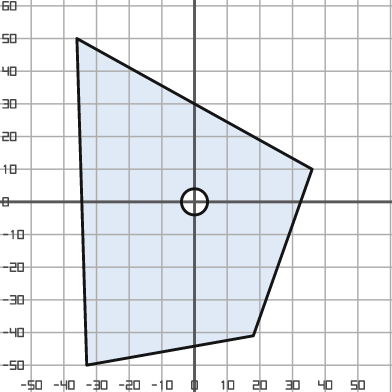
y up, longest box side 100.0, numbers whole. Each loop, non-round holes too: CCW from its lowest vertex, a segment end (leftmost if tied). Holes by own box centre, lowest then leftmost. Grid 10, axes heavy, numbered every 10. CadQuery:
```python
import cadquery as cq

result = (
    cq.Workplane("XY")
    .moveTo(-33.0, -50.0)
    .lineTo(18.0, -41.0)
    .lineTo(36.0, 10.0)
    .lineTo(-36.0, 50.0)
    .close()
    .moveTo(0.0, 0.0)
    .circle(4.0)
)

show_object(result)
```